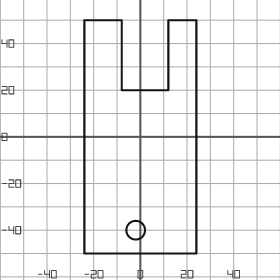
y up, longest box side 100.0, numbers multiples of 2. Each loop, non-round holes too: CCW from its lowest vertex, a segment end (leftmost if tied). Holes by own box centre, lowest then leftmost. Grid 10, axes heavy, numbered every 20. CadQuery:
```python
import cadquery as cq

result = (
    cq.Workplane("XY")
    .moveTo(-24.0, -50.0)
    .lineTo(24.0, -50.0)
    .lineTo(24.0, 50.0)
    .lineTo(12.0, 50.0)
    .lineTo(12.0, 20.0)
    .lineTo(-8.0, 20.0)
    .lineTo(-8.0, 50.0)
    .lineTo(-24.0, 50.0)
    .close()
    .moveTo(-2.0, -40.0)
    .circle(4.0)
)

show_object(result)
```